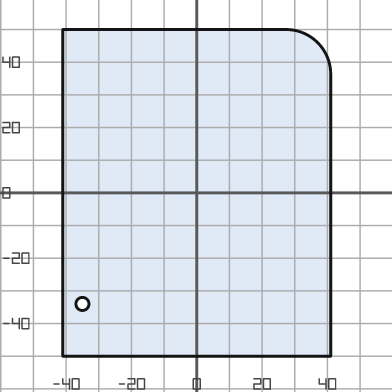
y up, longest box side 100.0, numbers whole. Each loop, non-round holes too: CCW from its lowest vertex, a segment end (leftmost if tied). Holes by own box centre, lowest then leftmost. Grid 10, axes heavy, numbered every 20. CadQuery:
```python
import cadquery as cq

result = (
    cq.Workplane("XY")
    .moveTo(-41.0, -50.0)
    .lineTo(41.0, -50.0)
    .lineTo(41.0, 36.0)
    .threePointArc((37.0, 46.0), (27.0, 50.0))
    .lineTo(-41.0, 50.0)
    .close()
    .moveTo(-35.0, -34.0)
    .circle(2.0)
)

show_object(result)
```